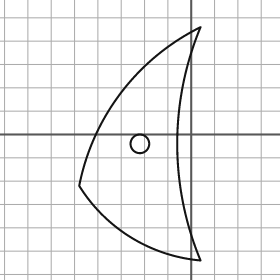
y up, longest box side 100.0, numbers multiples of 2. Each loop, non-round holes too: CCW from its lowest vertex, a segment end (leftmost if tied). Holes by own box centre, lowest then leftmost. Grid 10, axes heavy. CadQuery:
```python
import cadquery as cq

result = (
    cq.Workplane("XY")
    .moveTo(4.0, -54.0)
    .threePointArc((-6.0, -4.0), (4.0, 46.0))
    .threePointArc((-30.0, 18.0), (-48.0, -22.0))
    .threePointArc((-26.0, -44.0), (4.0, -54.0))
    .close()
    .moveTo(-22.0, -4.0)
    .circle(4.0)
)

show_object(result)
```